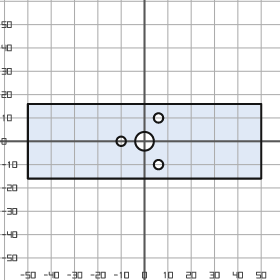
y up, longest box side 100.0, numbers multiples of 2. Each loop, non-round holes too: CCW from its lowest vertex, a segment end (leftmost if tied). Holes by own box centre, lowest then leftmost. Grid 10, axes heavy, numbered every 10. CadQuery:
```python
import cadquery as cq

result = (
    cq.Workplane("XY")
    .moveTo(-50.0, -16.0)
    .lineTo(50.0, -16.0)
    .lineTo(50.0, 16.0)
    .lineTo(-50.0, 16.0)
    .close()
    .moveTo(6.0, -10.0)
    .circle(2.0)
    .moveTo(-10.0, 0.0)
    .circle(2.0)
    .moveTo(0.0, 0.0)
    .circle(4.0)
    .moveTo(6.0, 10.0)
    .circle(2.0)
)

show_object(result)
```